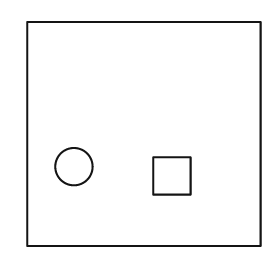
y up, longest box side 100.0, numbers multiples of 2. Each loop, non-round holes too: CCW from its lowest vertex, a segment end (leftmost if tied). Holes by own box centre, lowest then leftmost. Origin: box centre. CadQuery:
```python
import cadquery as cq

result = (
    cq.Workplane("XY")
    .moveTo(-50.0, -48.0)
    .lineTo(50.0, -48.0)
    .lineTo(50.0, 48.0)
    .lineTo(-50.0, 48.0)
    .close()
    .moveTo(4.0, -26.0)
    .lineTo(20.0, -26.0)
    .lineTo(20.0, -10.0)
    .lineTo(4.0, -10.0)
    .close()
    .moveTo(-30.0, -14.0)
    .circle(8.0)
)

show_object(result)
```